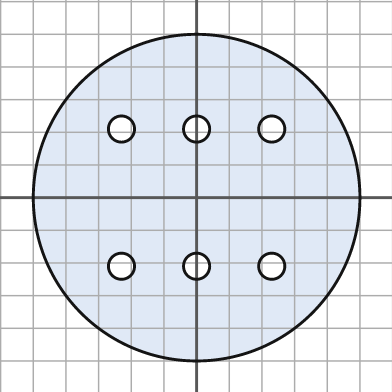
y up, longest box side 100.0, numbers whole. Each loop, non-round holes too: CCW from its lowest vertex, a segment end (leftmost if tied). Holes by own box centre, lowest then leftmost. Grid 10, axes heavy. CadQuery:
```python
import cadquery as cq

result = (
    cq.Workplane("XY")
    .moveTo(0.0, 0.0)
    .circle(50.0)
    .moveTo(-23.0, -21.0)
    .circle(4.0)
    .moveTo(0.0, -21.0)
    .circle(4.0)
    .moveTo(23.0, -21.0)
    .circle(4.0)
    .moveTo(-23.0, 21.0)
    .circle(4.0)
    .moveTo(0.0, 21.0)
    .circle(4.0)
    .moveTo(23.0, 21.0)
    .circle(4.0)
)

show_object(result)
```